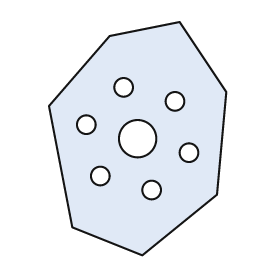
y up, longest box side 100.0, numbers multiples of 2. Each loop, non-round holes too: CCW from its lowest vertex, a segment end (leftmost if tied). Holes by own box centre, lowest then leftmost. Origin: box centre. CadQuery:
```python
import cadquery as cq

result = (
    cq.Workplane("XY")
    .moveTo(2.0, -50.0)
    .lineTo(34.0, -24.0)
    .lineTo(38.0, 20.0)
    .lineTo(18.0, 50.0)
    .lineTo(-12.0, 44.0)
    .lineTo(-38.0, 14.0)
    .lineTo(-28.0, -38.0)
    .close()
    .moveTo(6.0, -22.0)
    .circle(4.0)
    .moveTo(-16.0, -16.0)
    .circle(4.0)
    .moveTo(22.0, -6.0)
    .circle(4.0)
    .moveTo(0.0, 0.0)
    .circle(8.0)
    .moveTo(-22.0, 6.0)
    .circle(4.0)
    .moveTo(16.0, 16.0)
    .circle(4.0)
    .moveTo(-6.0, 22.0)
    .circle(4.0)
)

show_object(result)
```